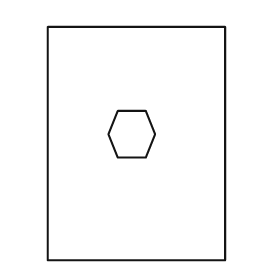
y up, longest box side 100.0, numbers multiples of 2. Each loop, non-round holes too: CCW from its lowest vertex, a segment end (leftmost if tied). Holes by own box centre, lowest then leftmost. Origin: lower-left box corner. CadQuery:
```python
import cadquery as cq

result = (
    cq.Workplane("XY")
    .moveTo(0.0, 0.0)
    .lineTo(76.0, 0.0)
    .lineTo(76.0, 100.0)
    .lineTo(0.0, 100.0)
    .close()
    .moveTo(30.0, 44.0)
    .lineTo(42.0, 44.0)
    .lineTo(46.0, 54.0)
    .lineTo(42.0, 64.0)
    .lineTo(30.0, 64.0)
    .lineTo(26.0, 54.0)
    .close()
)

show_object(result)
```